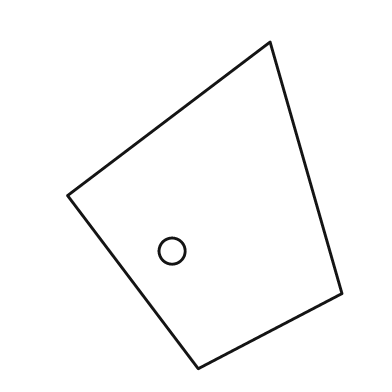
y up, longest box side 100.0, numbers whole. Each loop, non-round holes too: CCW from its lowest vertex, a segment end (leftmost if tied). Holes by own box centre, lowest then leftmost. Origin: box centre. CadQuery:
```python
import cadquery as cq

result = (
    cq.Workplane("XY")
    .moveTo(-2.0, -50.0)
    .lineTo(42.0, -27.0)
    .lineTo(20.0, 50.0)
    .lineTo(-42.0, 3.0)
    .close()
    .moveTo(-10.0, -14.0)
    .circle(4.0)
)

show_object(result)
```